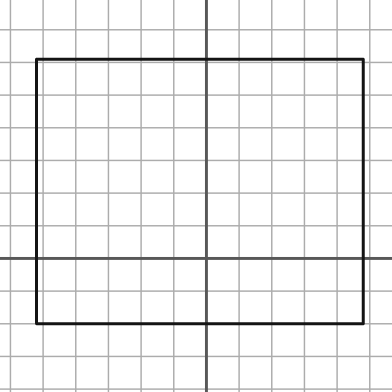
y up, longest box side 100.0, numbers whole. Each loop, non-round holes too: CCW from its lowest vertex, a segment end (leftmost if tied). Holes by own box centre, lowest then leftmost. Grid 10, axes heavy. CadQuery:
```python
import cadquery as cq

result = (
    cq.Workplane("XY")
    .moveTo(-52.0, -20.0)
    .lineTo(48.0, -20.0)
    .lineTo(48.0, 61.0)
    .lineTo(-52.0, 61.0)
    .close()
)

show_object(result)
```